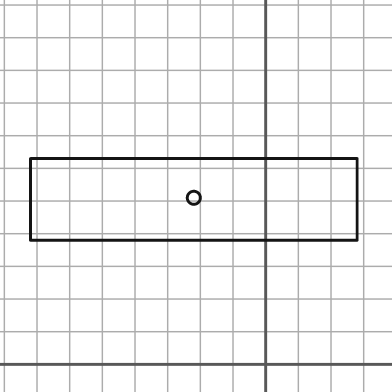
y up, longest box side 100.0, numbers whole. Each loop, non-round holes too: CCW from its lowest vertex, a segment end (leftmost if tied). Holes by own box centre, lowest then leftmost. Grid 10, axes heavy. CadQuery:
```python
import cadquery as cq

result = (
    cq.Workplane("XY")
    .moveTo(-72.0, 38.0)
    .lineTo(28.0, 38.0)
    .lineTo(28.0, 63.0)
    .lineTo(-72.0, 63.0)
    .close()
    .moveTo(-22.0, 51.0)
    .circle(2.0)
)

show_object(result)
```